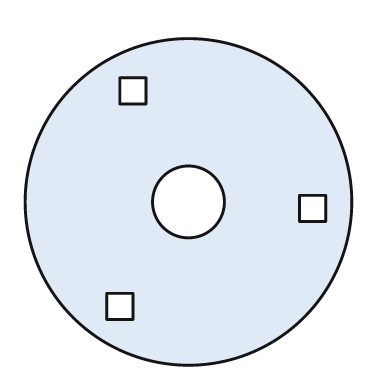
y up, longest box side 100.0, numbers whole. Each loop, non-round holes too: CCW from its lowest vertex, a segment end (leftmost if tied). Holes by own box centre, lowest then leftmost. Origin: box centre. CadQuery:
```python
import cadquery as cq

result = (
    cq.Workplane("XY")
    .moveTo(0.0, 0.0)
    .circle(50.0)
    .moveTo(-25.0, -36.0)
    .lineTo(-17.0, -36.0)
    .lineTo(-17.0, -28.0)
    .lineTo(-25.0, -28.0)
    .close()
    .moveTo(34.0, -6.0)
    .lineTo(42.0, -6.0)
    .lineTo(42.0, 2.0)
    .lineTo(34.0, 2.0)
    .close()
    .moveTo(0.0, 0.0)
    .circle(11.0)
    .moveTo(-21.0, 30.0)
    .lineTo(-13.0, 30.0)
    .lineTo(-13.0, 38.0)
    .lineTo(-21.0, 38.0)
    .close()
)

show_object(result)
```